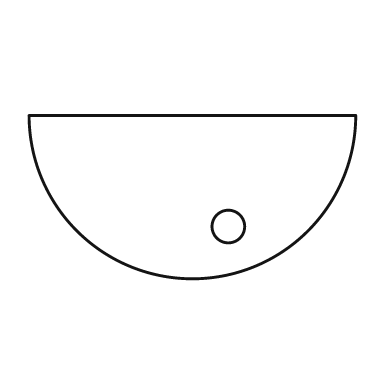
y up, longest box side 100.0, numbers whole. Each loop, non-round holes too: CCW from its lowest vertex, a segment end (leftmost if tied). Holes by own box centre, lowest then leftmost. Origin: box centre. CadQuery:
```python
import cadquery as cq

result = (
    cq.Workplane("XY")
    .moveTo(-50.0, 25.0)
    .threePointArc((0.0, -25.0), (50.0, 25.0))
    .close()
    .moveTo(11.0, -9.0)
    .circle(5.0)
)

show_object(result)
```